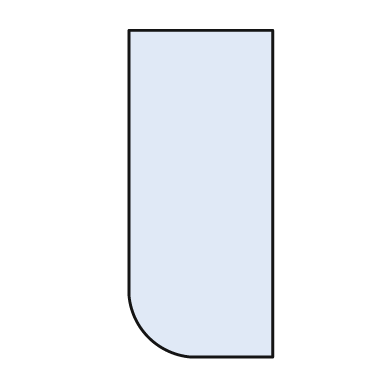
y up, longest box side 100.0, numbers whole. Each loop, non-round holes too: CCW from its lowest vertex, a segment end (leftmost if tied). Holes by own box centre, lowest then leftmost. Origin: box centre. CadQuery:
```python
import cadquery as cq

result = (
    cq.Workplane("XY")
    .moveTo(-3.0, -50.0)
    .lineTo(22.0, -50.0)
    .lineTo(22.0, 50.0)
    .lineTo(-22.0, 50.0)
    .lineTo(-22.0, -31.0)
    .threePointArc((-16.0, -44.0), (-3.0, -50.0))
    .close()
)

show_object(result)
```